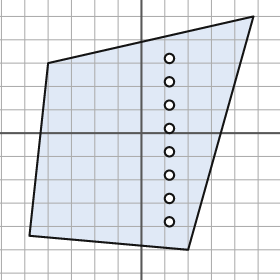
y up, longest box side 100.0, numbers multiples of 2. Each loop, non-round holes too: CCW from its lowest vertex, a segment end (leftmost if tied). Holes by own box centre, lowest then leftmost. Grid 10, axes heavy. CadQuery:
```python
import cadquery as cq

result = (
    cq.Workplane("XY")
    .moveTo(20.0, -50.0)
    .lineTo(48.0, 50.0)
    .lineTo(-40.0, 30.0)
    .lineTo(-48.0, -44.0)
    .close()
    .moveTo(12.0, -38.0)
    .circle(2.0)
    .moveTo(12.0, -28.0)
    .circle(2.0)
    .moveTo(12.0, -18.0)
    .circle(2.0)
    .moveTo(12.0, -8.0)
    .circle(2.0)
    .moveTo(12.0, 2.0)
    .circle(2.0)
    .moveTo(12.0, 12.0)
    .circle(2.0)
    .moveTo(12.0, 22.0)
    .circle(2.0)
    .moveTo(12.0, 32.0)
    .circle(2.0)
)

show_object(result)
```